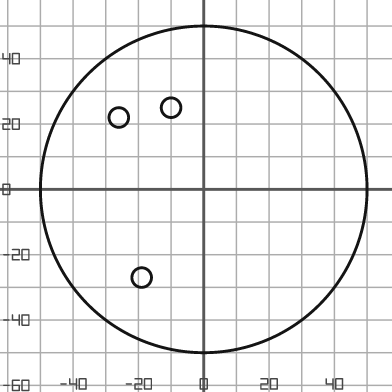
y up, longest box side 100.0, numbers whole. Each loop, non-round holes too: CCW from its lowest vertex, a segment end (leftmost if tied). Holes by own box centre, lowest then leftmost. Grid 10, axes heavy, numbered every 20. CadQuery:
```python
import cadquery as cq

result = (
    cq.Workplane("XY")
    .moveTo(0.0, 0.0)
    .circle(50.0)
    .moveTo(-19.0, -27.0)
    .circle(3.0)
    .moveTo(-26.0, 22.0)
    .circle(3.0)
    .moveTo(-10.0, 25.0)
    .circle(3.0)
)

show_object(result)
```